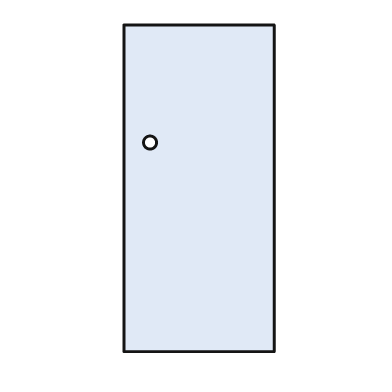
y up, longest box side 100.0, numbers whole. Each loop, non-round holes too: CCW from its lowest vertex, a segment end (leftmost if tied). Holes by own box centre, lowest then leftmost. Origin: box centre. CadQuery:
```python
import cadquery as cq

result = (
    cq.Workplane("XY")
    .moveTo(-23.0, -50.0)
    .lineTo(23.0, -50.0)
    .lineTo(23.0, 50.0)
    .lineTo(-23.0, 50.0)
    .close()
    .moveTo(-15.0, 14.0)
    .circle(2.0)
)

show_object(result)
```